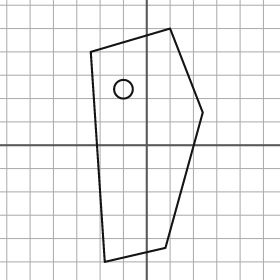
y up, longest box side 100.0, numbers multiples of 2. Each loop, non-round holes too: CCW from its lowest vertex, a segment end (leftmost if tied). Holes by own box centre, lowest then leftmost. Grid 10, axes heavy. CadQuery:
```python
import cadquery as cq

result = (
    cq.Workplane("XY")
    .moveTo(-18.0, -50.0)
    .lineTo(8.0, -44.0)
    .lineTo(24.0, 14.0)
    .lineTo(10.0, 50.0)
    .lineTo(-24.0, 40.0)
    .close()
    .moveTo(-10.0, 24.0)
    .circle(4.0)
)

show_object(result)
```